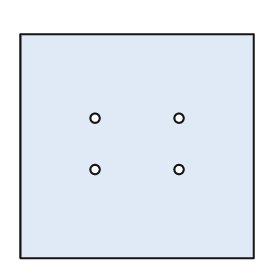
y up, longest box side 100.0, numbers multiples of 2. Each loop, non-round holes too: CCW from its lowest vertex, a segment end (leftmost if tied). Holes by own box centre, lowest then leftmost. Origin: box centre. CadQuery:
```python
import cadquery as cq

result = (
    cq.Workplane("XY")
    .moveTo(-50.0, -48.0)
    .lineTo(50.0, -48.0)
    .lineTo(50.0, 48.0)
    .lineTo(-50.0, 48.0)
    .close()
    .moveTo(-18.0, -10.0)
    .circle(2.0)
    .moveTo(18.0, -10.0)
    .circle(2.0)
    .moveTo(-18.0, 12.0)
    .circle(2.0)
    .moveTo(18.0, 12.0)
    .circle(2.0)
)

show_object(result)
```